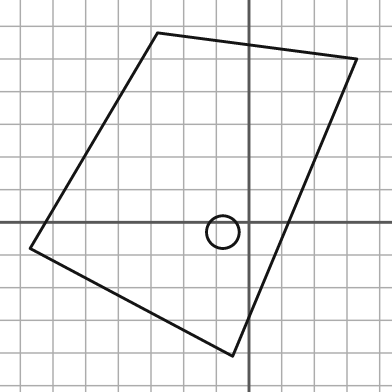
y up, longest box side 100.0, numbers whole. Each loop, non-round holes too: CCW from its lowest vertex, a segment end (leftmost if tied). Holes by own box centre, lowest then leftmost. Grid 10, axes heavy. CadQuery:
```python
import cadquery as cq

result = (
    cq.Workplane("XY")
    .moveTo(-5.0, -41.0)
    .lineTo(33.0, 50.0)
    .lineTo(-28.0, 58.0)
    .lineTo(-67.0, -8.0)
    .close()
    .moveTo(-8.0, -3.0)
    .circle(5.0)
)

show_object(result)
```